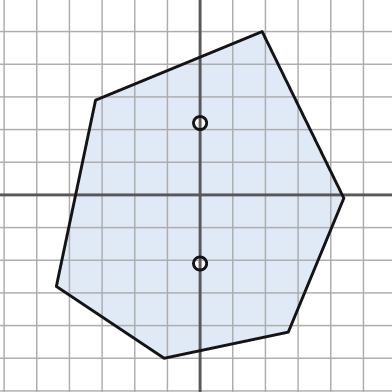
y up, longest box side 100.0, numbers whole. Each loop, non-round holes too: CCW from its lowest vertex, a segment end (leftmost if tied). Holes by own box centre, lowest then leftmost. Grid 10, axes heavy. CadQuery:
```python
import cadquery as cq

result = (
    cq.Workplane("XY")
    .moveTo(-11.0, -50.0)
    .lineTo(27.0, -42.0)
    .lineTo(44.0, -1.0)
    .lineTo(19.0, 50.0)
    .lineTo(-32.0, 29.0)
    .lineTo(-44.0, -28.0)
    .close()
    .moveTo(0.0, -21.0)
    .circle(2.0)
    .moveTo(0.0, 22.0)
    .circle(2.0)
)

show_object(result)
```